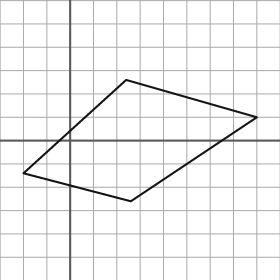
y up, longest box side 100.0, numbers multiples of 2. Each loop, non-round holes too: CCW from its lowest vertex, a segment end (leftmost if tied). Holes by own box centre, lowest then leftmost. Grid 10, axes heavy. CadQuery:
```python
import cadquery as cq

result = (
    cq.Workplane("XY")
    .moveTo(26.0, -26.0)
    .lineTo(80.0, 10.0)
    .lineTo(24.0, 26.0)
    .lineTo(-20.0, -14.0)
    .close()
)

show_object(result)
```